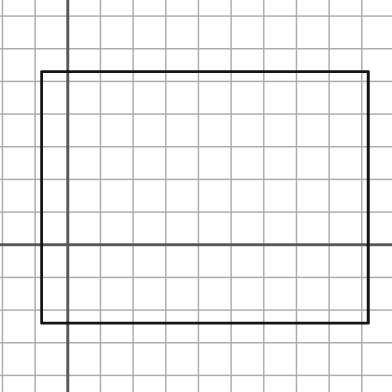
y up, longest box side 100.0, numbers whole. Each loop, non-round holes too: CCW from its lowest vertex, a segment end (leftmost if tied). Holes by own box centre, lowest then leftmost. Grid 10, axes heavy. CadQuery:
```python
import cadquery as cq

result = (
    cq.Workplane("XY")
    .moveTo(-8.0, -24.0)
    .lineTo(92.0, -24.0)
    .lineTo(92.0, 53.0)
    .lineTo(-8.0, 53.0)
    .close()
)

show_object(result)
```